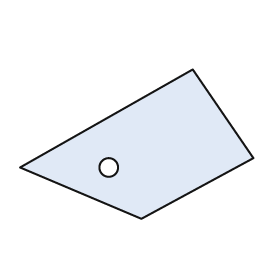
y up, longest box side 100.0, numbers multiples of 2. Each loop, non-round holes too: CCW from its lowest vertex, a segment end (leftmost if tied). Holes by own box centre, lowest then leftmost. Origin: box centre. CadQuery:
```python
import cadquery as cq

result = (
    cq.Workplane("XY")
    .moveTo(2.0, -32.0)
    .lineTo(50.0, -6.0)
    .lineTo(24.0, 32.0)
    .lineTo(-50.0, -10.0)
    .close()
    .moveTo(-12.0, -10.0)
    .circle(4.0)
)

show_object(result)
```